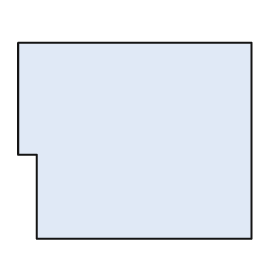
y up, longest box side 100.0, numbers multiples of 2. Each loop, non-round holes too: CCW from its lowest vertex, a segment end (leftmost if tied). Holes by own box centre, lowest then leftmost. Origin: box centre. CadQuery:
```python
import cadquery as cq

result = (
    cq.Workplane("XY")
    .moveTo(-42.0, -42.0)
    .lineTo(50.0, -42.0)
    .lineTo(50.0, 42.0)
    .lineTo(-50.0, 42.0)
    .lineTo(-50.0, -6.0)
    .lineTo(-42.0, -6.0)
    .close()
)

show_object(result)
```